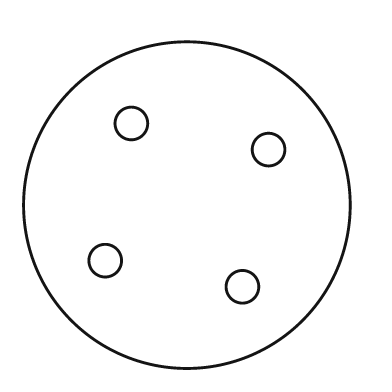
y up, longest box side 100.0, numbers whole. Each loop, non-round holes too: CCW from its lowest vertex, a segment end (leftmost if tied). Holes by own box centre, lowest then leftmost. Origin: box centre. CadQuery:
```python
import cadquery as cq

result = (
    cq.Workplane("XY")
    .moveTo(0.0, 0.0)
    .circle(50.0)
    .moveTo(17.0, -25.0)
    .circle(5.0)
    .moveTo(-25.0, -17.0)
    .circle(5.0)
    .moveTo(25.0, 17.0)
    .circle(5.0)
    .moveTo(-17.0, 25.0)
    .circle(5.0)
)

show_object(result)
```